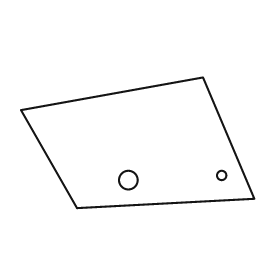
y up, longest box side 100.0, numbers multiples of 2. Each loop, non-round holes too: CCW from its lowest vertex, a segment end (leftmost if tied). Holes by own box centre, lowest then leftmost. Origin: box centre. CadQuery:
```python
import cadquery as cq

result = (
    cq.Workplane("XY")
    .moveTo(-26.0, -28.0)
    .lineTo(50.0, -24.0)
    .lineTo(28.0, 28.0)
    .lineTo(-50.0, 14.0)
    .close()
    .moveTo(-4.0, -16.0)
    .circle(4.0)
    .moveTo(36.0, -14.0)
    .circle(2.0)
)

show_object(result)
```